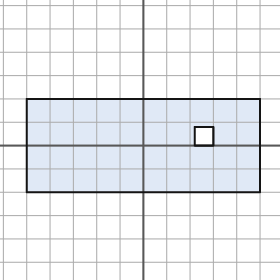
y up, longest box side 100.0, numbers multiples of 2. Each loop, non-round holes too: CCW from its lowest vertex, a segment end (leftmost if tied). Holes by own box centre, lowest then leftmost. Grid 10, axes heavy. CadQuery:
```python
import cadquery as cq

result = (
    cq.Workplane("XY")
    .moveTo(-50.0, -20.0)
    .lineTo(50.0, -20.0)
    .lineTo(50.0, 20.0)
    .lineTo(-50.0, 20.0)
    .close()
    .moveTo(22.0, 0.0)
    .lineTo(30.0, 0.0)
    .lineTo(30.0, 8.0)
    .lineTo(22.0, 8.0)
    .close()
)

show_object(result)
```